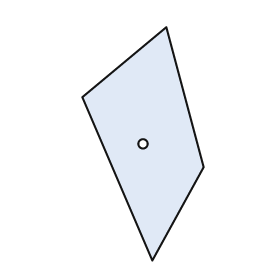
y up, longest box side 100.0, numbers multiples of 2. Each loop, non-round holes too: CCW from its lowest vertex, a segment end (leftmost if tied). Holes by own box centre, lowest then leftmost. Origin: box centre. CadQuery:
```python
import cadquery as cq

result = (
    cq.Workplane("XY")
    .moveTo(4.0, -50.0)
    .lineTo(26.0, -10.0)
    .lineTo(10.0, 50.0)
    .lineTo(-26.0, 20.0)
    .close()
    .moveTo(0.0, 0.0)
    .circle(2.0)
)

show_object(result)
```